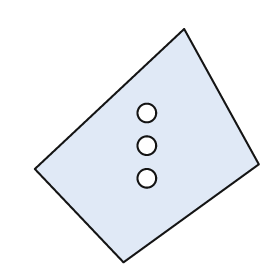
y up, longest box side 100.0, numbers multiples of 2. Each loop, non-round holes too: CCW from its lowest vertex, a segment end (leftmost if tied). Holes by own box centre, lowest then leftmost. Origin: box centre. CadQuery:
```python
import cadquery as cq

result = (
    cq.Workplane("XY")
    .moveTo(-10.0, -50.0)
    .lineTo(48.0, -8.0)
    .lineTo(16.0, 50.0)
    .lineTo(-48.0, -10.0)
    .close()
    .moveTo(0.0, -14.0)
    .circle(4.0)
    .moveTo(0.0, 0.0)
    .circle(4.0)
    .moveTo(0.0, 14.0)
    .circle(4.0)
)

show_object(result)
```